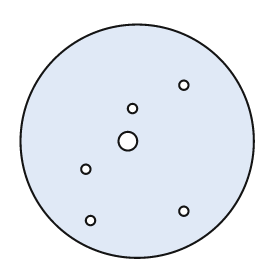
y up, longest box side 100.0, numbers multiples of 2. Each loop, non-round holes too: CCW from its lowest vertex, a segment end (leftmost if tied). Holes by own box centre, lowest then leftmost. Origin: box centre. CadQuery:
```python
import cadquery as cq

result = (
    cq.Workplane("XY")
    .moveTo(0.0, 0.0)
    .circle(50.0)
    .moveTo(-20.0, -34.0)
    .circle(2.0)
    .moveTo(20.0, -30.0)
    .circle(2.0)
    .moveTo(-22.0, -12.0)
    .circle(2.0)
    .moveTo(-4.0, 0.0)
    .circle(4.0)
    .moveTo(-2.0, 14.0)
    .circle(2.0)
    .moveTo(20.0, 24.0)
    .circle(2.0)
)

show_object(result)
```